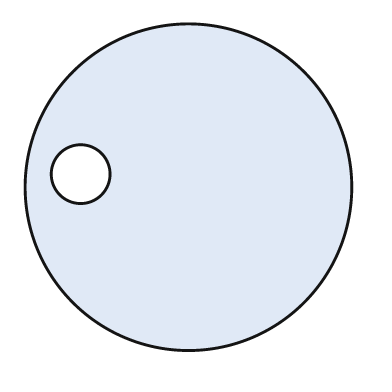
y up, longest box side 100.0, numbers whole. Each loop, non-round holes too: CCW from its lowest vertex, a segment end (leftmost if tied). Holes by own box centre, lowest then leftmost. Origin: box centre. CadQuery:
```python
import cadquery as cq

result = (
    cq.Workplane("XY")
    .moveTo(0.0, 0.0)
    .circle(50.0)
    .moveTo(-33.0, 4.0)
    .circle(9.0)
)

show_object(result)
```